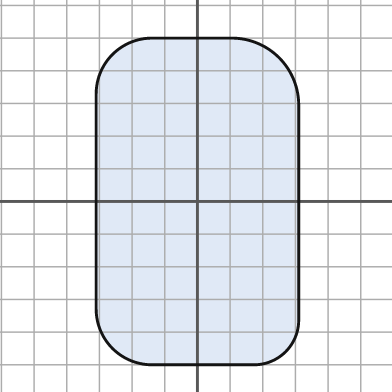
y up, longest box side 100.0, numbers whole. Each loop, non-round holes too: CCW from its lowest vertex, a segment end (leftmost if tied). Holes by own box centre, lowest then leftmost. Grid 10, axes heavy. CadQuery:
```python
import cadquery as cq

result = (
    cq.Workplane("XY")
    .moveTo(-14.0, -50.0)
    .lineTo(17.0, -50.0)
    .threePointArc((27.0, -46.0), (31.0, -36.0))
    .lineTo(31.0, 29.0)
    .threePointArc((25.0, 44.0), (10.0, 50.0))
    .lineTo(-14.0, 50.0)
    .threePointArc((-26.0, 45.0), (-31.0, 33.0))
    .lineTo(-31.0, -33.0)
    .threePointArc((-26.0, -45.0), (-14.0, -50.0))
    .close()
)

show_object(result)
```